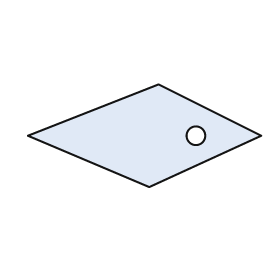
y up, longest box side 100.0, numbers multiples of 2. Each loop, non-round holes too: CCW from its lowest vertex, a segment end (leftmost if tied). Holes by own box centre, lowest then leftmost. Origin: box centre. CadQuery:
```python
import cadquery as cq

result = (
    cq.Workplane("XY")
    .moveTo(2.0, -22.0)
    .lineTo(50.0, 0.0)
    .lineTo(6.0, 22.0)
    .lineTo(-50.0, 0.0)
    .close()
    .moveTo(22.0, 0.0)
    .circle(4.0)
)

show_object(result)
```